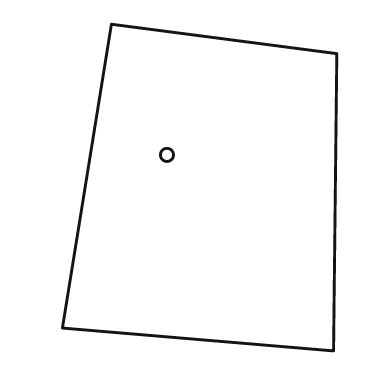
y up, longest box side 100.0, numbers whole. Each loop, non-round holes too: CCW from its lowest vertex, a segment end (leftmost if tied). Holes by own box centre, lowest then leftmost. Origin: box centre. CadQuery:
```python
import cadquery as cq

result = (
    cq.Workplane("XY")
    .moveTo(41.0, -50.0)
    .lineTo(42.0, 41.0)
    .lineTo(-27.0, 50.0)
    .lineTo(-42.0, -43.0)
    .close()
    .moveTo(-10.0, 10.0)
    .circle(2.0)
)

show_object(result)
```